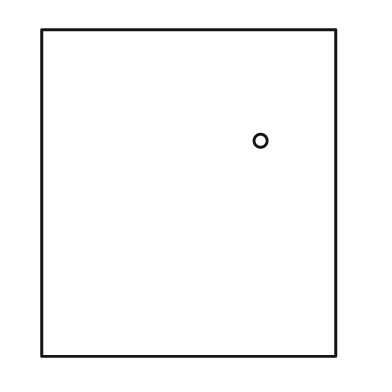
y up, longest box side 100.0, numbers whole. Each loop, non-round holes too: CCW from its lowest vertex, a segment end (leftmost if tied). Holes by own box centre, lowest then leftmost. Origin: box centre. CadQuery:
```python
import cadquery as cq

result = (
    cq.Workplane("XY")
    .moveTo(-45.0, -50.0)
    .lineTo(45.0, -50.0)
    .lineTo(45.0, 50.0)
    .lineTo(-45.0, 50.0)
    .close()
    .moveTo(22.0, 16.0)
    .circle(2.0)
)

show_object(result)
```